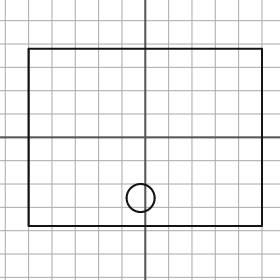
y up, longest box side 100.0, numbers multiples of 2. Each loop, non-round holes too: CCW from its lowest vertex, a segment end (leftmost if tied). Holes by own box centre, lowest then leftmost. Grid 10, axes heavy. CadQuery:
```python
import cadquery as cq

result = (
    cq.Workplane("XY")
    .moveTo(-50.0, -38.0)
    .lineTo(50.0, -38.0)
    .lineTo(50.0, 38.0)
    .lineTo(-50.0, 38.0)
    .close()
    .moveTo(-2.0, -26.0)
    .circle(6.0)
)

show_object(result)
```